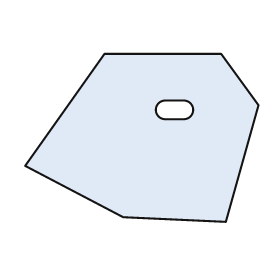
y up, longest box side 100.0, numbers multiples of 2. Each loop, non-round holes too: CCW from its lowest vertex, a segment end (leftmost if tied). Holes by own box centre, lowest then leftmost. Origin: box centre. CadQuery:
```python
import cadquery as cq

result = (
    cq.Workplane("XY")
    .moveTo(36.0, -36.0)
    .lineTo(50.0, 14.0)
    .lineTo(34.0, 36.0)
    .lineTo(-16.0, 36.0)
    .lineTo(-50.0, -12.0)
    .lineTo(-8.0, -34.0)
    .close()
    .moveTo(10.0, 8.0)
    .lineTo(18.0, 8.0)
    .threePointArc((22.0, 12.0), (18.0, 16.0))
    .lineTo(10.0, 16.0)
    .threePointArc((6.0, 12.0), (10.0, 8.0))
    .close()
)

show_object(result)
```